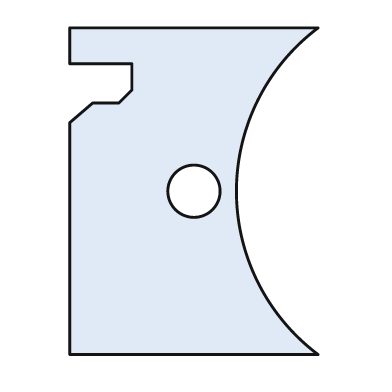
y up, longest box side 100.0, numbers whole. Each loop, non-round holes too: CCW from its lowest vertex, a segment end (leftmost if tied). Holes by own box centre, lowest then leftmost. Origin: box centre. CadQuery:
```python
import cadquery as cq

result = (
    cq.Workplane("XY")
    .moveTo(-38.0, -50.0)
    .lineTo(38.0, -50.0)
    .threePointArc((13.0, 0.0), (38.0, 50.0))
    .lineTo(-38.0, 50.0)
    .lineTo(-38.0, 39.0)
    .lineTo(-19.0, 39.0)
    .lineTo(-19.0, 31.0)
    .lineTo(-23.0, 27.0)
    .lineTo(-31.0, 27.0)
    .lineTo(-38.0, 21.0)
    .close()
    .moveTo(0.0, 0.0)
    .circle(8.0)
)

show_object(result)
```